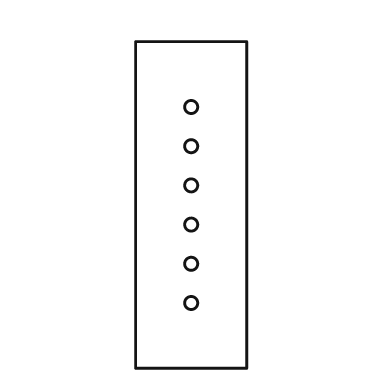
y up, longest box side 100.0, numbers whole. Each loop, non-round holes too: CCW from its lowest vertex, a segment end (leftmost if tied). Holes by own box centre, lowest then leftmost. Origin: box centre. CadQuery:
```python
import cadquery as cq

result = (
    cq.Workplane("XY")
    .moveTo(-17.0, -50.0)
    .lineTo(17.0, -50.0)
    .lineTo(17.0, 50.0)
    .lineTo(-17.0, 50.0)
    .close()
    .moveTo(0.0, -30.0)
    .circle(2.0)
    .moveTo(0.0, -18.0)
    .circle(2.0)
    .moveTo(0.0, -6.0)
    .circle(2.0)
    .moveTo(0.0, 6.0)
    .circle(2.0)
    .moveTo(0.0, 18.0)
    .circle(2.0)
    .moveTo(0.0, 30.0)
    .circle(2.0)
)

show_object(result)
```